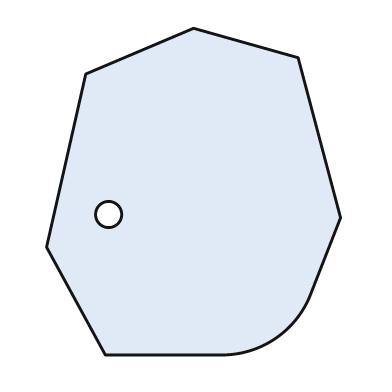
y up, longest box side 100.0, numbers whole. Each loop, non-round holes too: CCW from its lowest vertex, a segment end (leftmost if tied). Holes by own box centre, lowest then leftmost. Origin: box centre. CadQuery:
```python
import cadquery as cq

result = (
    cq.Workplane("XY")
    .moveTo(-27.0, -50.0)
    .lineTo(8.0, -50.0)
    .threePointArc((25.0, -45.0), (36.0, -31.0))
    .lineTo(45.0, -8.0)
    .lineTo(32.0, 41.0)
    .lineTo(0.0, 50.0)
    .lineTo(-33.0, 36.0)
    .lineTo(-45.0, -17.0)
    .close()
    .moveTo(-26.0, -7.0)
    .circle(4.0)
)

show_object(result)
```